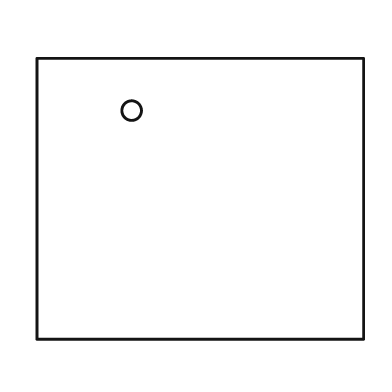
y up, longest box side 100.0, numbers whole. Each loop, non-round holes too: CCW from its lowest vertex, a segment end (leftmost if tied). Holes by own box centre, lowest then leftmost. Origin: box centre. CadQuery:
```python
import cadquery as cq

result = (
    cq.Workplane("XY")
    .moveTo(-50.0, -43.0)
    .lineTo(50.0, -43.0)
    .lineTo(50.0, 43.0)
    .lineTo(-50.0, 43.0)
    .close()
    .moveTo(-21.0, 27.0)
    .circle(3.0)
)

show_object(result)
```